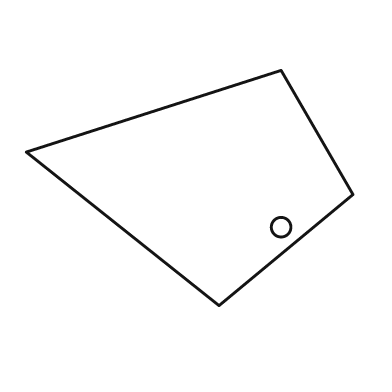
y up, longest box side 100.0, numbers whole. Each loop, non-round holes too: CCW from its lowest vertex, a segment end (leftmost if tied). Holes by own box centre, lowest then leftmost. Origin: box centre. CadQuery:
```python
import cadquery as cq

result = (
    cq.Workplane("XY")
    .moveTo(9.0, -36.0)
    .lineTo(50.0, -2.0)
    .lineTo(28.0, 36.0)
    .lineTo(-50.0, 11.0)
    .close()
    .moveTo(28.0, -12.0)
    .circle(3.0)
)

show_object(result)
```